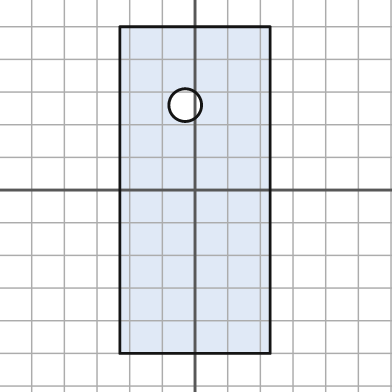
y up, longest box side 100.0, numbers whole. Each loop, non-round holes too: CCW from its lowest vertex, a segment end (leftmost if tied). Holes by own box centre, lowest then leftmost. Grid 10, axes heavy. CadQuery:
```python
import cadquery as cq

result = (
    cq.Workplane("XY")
    .moveTo(-23.0, -50.0)
    .lineTo(23.0, -50.0)
    .lineTo(23.0, 50.0)
    .lineTo(-23.0, 50.0)
    .close()
    .moveTo(-3.0, 26.0)
    .circle(5.0)
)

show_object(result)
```